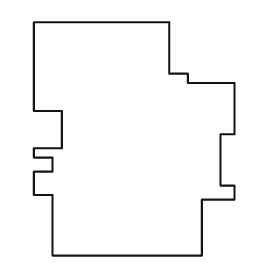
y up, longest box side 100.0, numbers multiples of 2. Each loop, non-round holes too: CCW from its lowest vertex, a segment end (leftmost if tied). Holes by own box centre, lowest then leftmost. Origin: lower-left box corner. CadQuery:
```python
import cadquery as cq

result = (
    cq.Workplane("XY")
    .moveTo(8.0, 0.0)
    .lineTo(72.0, 0.0)
    .lineTo(72.0, 24.0)
    .lineTo(86.0, 24.0)
    .lineTo(86.0, 30.0)
    .lineTo(80.0, 30.0)
    .lineTo(80.0, 52.0)
    .lineTo(86.0, 52.0)
    .lineTo(86.0, 74.0)
    .lineTo(66.0, 74.0)
    .lineTo(66.0, 78.0)
    .lineTo(58.0, 78.0)
    .lineTo(58.0, 100.0)
    .lineTo(0.0, 100.0)
    .lineTo(0.0, 62.0)
    .lineTo(12.0, 62.0)
    .lineTo(12.0, 46.0)
    .lineTo(0.0, 46.0)
    .lineTo(0.0, 42.0)
    .lineTo(8.0, 42.0)
    .lineTo(8.0, 36.0)
    .lineTo(0.0, 36.0)
    .lineTo(0.0, 26.0)
    .lineTo(8.0, 26.0)
    .close()
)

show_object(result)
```